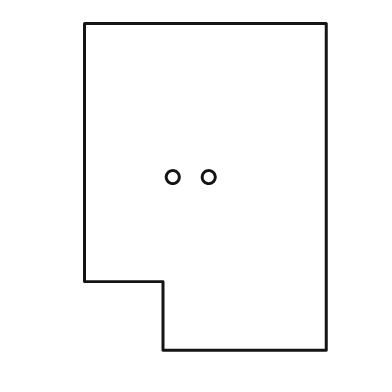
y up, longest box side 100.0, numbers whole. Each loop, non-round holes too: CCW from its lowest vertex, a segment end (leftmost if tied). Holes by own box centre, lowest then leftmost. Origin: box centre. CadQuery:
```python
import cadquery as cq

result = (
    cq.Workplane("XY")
    .moveTo(-13.0, -50.0)
    .lineTo(37.0, -50.0)
    .lineTo(37.0, 50.0)
    .lineTo(-37.0, 50.0)
    .lineTo(-37.0, -29.0)
    .lineTo(-13.0, -29.0)
    .close()
    .moveTo(-10.0, 3.0)
    .circle(2.0)
    .moveTo(1.0, 3.0)
    .circle(2.0)
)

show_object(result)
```